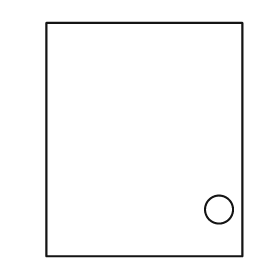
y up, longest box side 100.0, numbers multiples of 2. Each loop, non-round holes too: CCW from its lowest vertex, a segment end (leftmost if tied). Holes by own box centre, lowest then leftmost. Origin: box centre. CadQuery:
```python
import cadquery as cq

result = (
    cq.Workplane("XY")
    .moveTo(-42.0, -50.0)
    .lineTo(42.0, -50.0)
    .lineTo(42.0, 50.0)
    .lineTo(-42.0, 50.0)
    .close()
    .moveTo(32.0, -30.0)
    .circle(6.0)
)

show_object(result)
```